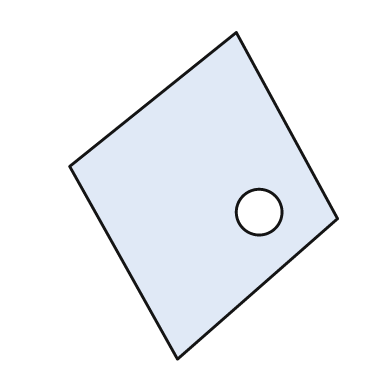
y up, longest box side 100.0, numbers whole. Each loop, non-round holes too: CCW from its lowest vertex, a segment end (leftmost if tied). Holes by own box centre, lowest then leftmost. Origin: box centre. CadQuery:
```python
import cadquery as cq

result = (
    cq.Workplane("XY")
    .moveTo(-8.0, -50.0)
    .lineTo(41.0, -7.0)
    .lineTo(10.0, 50.0)
    .lineTo(-41.0, 9.0)
    .close()
    .moveTo(17.0, -5.0)
    .circle(7.0)
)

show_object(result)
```